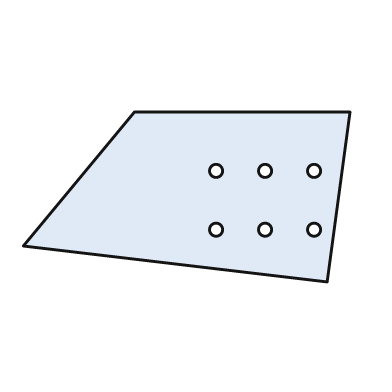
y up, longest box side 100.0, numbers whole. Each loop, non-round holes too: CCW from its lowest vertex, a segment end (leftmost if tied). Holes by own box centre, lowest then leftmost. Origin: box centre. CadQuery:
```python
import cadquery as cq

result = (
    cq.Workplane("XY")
    .moveTo(43.0, -26.0)
    .lineTo(50.0, 26.0)
    .lineTo(-16.0, 26.0)
    .lineTo(-50.0, -15.0)
    .close()
    .moveTo(9.0, -10.0)
    .circle(2.0)
    .moveTo(24.0, -10.0)
    .circle(2.0)
    .moveTo(39.0, -10.0)
    .circle(2.0)
    .moveTo(9.0, 8.0)
    .circle(2.0)
    .moveTo(24.0, 8.0)
    .circle(2.0)
    .moveTo(39.0, 8.0)
    .circle(2.0)
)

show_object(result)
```